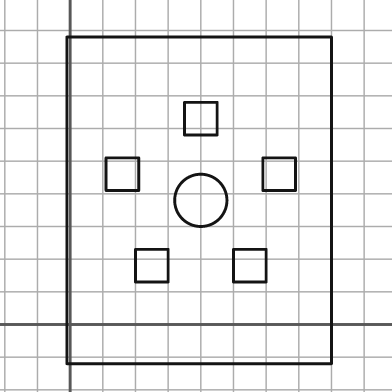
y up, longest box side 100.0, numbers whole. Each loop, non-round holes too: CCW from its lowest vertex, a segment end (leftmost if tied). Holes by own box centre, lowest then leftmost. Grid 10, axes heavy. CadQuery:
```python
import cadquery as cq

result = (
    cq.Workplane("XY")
    .moveTo(-1.0, -12.0)
    .lineTo(80.0, -12.0)
    .lineTo(80.0, 88.0)
    .lineTo(-1.0, 88.0)
    .close()
    .moveTo(20.0, 13.0)
    .lineTo(30.0, 13.0)
    .lineTo(30.0, 23.0)
    .lineTo(20.0, 23.0)
    .close()
    .moveTo(50.0, 13.0)
    .lineTo(60.0, 13.0)
    .lineTo(60.0, 23.0)
    .lineTo(50.0, 23.0)
    .close()
    .moveTo(40.0, 38.0)
    .circle(8.0)
    .moveTo(11.0, 41.0)
    .lineTo(21.0, 41.0)
    .lineTo(21.0, 51.0)
    .lineTo(11.0, 51.0)
    .close()
    .moveTo(59.0, 41.0)
    .lineTo(69.0, 41.0)
    .lineTo(69.0, 51.0)
    .lineTo(59.0, 51.0)
    .close()
    .moveTo(35.0, 58.0)
    .lineTo(45.0, 58.0)
    .lineTo(45.0, 68.0)
    .lineTo(35.0, 68.0)
    .close()
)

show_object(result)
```